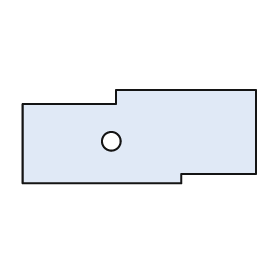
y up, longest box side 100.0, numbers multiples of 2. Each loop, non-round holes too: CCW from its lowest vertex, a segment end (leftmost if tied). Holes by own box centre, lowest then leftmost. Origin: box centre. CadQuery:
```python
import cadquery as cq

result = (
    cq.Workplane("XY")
    .moveTo(-50.0, -20.0)
    .lineTo(18.0, -20.0)
    .lineTo(18.0, -16.0)
    .lineTo(50.0, -16.0)
    .lineTo(50.0, 20.0)
    .lineTo(-10.0, 20.0)
    .lineTo(-10.0, 14.0)
    .lineTo(-50.0, 14.0)
    .close()
    .moveTo(-12.0, -2.0)
    .circle(4.0)
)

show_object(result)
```